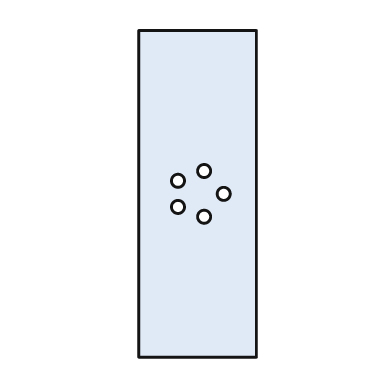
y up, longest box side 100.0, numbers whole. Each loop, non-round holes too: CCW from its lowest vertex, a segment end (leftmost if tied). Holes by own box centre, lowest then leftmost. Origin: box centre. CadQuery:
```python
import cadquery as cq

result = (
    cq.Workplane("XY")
    .moveTo(-18.0, -50.0)
    .lineTo(18.0, -50.0)
    .lineTo(18.0, 50.0)
    .lineTo(-18.0, 50.0)
    .close()
    .moveTo(2.0, -7.0)
    .circle(2.0)
    .moveTo(-6.0, -4.0)
    .circle(2.0)
    .moveTo(8.0, 0.0)
    .circle(2.0)
    .moveTo(-6.0, 4.0)
    .circle(2.0)
    .moveTo(2.0, 7.0)
    .circle(2.0)
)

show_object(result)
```